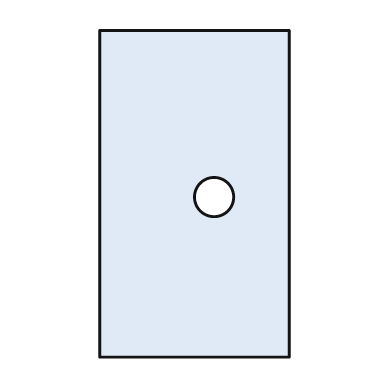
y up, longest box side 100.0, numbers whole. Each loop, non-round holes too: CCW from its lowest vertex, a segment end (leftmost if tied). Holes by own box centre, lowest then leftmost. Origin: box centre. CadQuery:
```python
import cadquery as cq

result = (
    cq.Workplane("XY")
    .moveTo(-29.0, -50.0)
    .lineTo(29.0, -50.0)
    .lineTo(29.0, 50.0)
    .lineTo(-29.0, 50.0)
    .close()
    .moveTo(6.0, -1.0)
    .circle(6.0)
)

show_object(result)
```